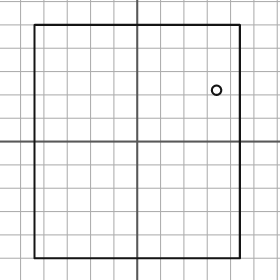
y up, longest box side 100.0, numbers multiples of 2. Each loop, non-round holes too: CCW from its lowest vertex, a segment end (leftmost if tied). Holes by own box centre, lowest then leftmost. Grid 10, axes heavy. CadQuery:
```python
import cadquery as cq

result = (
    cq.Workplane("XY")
    .moveTo(-44.0, -50.0)
    .lineTo(44.0, -50.0)
    .lineTo(44.0, 50.0)
    .lineTo(-44.0, 50.0)
    .close()
    .moveTo(34.0, 22.0)
    .circle(2.0)
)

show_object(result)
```